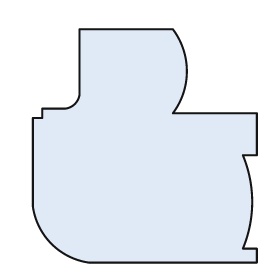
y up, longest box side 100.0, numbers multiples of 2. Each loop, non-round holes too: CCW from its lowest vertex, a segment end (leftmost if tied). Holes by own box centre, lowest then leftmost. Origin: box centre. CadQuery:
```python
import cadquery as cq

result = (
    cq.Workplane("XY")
    .moveTo(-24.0, -50.0)
    .lineTo(48.0, -50.0)
    .lineTo(48.0, -44.0)
    .lineTo(42.0, -44.0)
    .threePointArc((46.0, -24.0), (42.0, -4.0))
    .lineTo(48.0, -4.0)
    .lineTo(48.0, 14.0)
    .lineTo(12.0, 14.0)
    .threePointArc((18.0, 32.0), (12.0, 50.0))
    .lineTo(-28.0, 50.0)
    .lineTo(-28.0, 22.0)
    .threePointArc((-30.0, 18.0), (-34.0, 16.0))
    .lineTo(-44.0, 16.0)
    .lineTo(-44.0, 12.0)
    .lineTo(-48.0, 12.0)
    .lineTo(-48.0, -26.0)
    .threePointArc((-40.0, -42.0), (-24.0, -50.0))
    .close()
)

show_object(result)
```